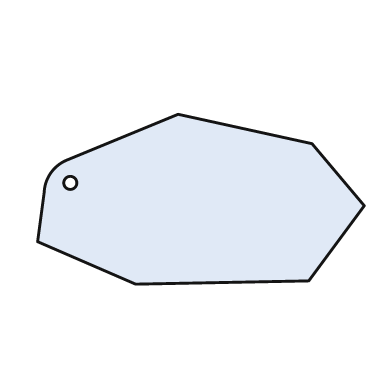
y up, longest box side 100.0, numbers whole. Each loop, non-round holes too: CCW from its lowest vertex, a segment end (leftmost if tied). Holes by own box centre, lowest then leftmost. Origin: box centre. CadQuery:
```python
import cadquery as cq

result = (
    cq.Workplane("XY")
    .moveTo(-20.0, -26.0)
    .lineTo(33.0, -25.0)
    .lineTo(50.0, -2.0)
    .lineTo(34.0, 17.0)
    .lineTo(-7.0, 26.0)
    .lineTo(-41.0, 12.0)
    .threePointArc((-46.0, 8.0), (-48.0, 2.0))
    .lineTo(-50.0, -13.0)
    .close()
    .moveTo(-40.0, 5.0)
    .circle(2.0)
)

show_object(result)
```